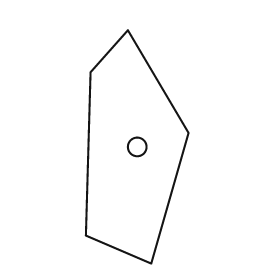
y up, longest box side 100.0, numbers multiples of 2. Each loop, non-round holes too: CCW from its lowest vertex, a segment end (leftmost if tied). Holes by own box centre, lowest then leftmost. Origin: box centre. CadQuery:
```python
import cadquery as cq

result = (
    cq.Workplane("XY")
    .moveTo(6.0, -50.0)
    .lineTo(22.0, 6.0)
    .lineTo(-4.0, 50.0)
    .lineTo(-20.0, 32.0)
    .lineTo(-22.0, -38.0)
    .close()
    .moveTo(0.0, 0.0)
    .circle(4.0)
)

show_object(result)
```